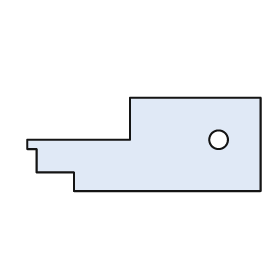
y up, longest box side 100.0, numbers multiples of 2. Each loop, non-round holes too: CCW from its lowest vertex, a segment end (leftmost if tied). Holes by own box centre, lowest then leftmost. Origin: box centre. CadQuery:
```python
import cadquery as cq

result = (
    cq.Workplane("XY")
    .moveTo(-30.0, -20.0)
    .lineTo(50.0, -20.0)
    .lineTo(50.0, 20.0)
    .lineTo(-6.0, 20.0)
    .lineTo(-6.0, 2.0)
    .lineTo(-50.0, 2.0)
    .lineTo(-50.0, -2.0)
    .lineTo(-46.0, -2.0)
    .lineTo(-46.0, -12.0)
    .lineTo(-30.0, -12.0)
    .close()
    .moveTo(32.0, 2.0)
    .circle(4.0)
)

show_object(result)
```